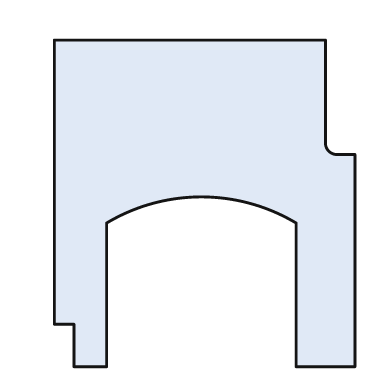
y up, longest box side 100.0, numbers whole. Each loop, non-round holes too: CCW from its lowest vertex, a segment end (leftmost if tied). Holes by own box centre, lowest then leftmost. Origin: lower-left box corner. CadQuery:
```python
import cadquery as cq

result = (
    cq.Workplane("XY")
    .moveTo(6.0, 0.0)
    .lineTo(16.0, 0.0)
    .lineTo(16.0, 44.0)
    .threePointArc((45.0, 52.0), (74.0, 44.0))
    .lineTo(74.0, 0.0)
    .lineTo(92.0, 0.0)
    .lineTo(92.0, 65.0)
    .lineTo(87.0, 65.0)
    .threePointArc((84.0, 66.0), (83.0, 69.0))
    .lineTo(83.0, 100.0)
    .lineTo(0.0, 100.0)
    .lineTo(0.0, 13.0)
    .lineTo(6.0, 13.0)
    .close()
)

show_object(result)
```